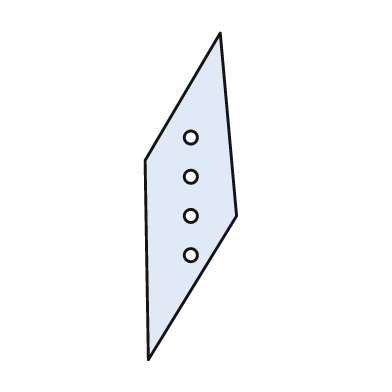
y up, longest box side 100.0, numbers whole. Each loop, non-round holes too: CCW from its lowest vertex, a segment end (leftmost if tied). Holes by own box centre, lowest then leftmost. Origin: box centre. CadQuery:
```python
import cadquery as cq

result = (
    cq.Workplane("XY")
    .moveTo(-13.0, -50.0)
    .lineTo(14.0, -6.0)
    .lineTo(9.0, 50.0)
    .lineTo(-14.0, 11.0)
    .close()
    .moveTo(0.0, -18.0)
    .circle(2.0)
    .moveTo(0.0, -6.0)
    .circle(2.0)
    .moveTo(0.0, 6.0)
    .circle(2.0)
    .moveTo(0.0, 18.0)
    .circle(2.0)
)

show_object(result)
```